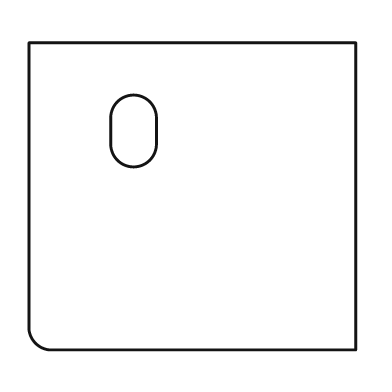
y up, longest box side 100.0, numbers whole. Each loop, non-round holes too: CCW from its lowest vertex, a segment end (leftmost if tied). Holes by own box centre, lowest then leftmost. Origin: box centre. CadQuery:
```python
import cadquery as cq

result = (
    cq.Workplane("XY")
    .moveTo(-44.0, -47.0)
    .lineTo(50.0, -47.0)
    .lineTo(50.0, 47.0)
    .lineTo(-50.0, 47.0)
    .lineTo(-50.0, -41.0)
    .threePointArc((-48.0, -45.0), (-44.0, -47.0))
    .close()
    .moveTo(-25.0, 16.0)
    .threePointArc((-18.0, 9.0), (-11.0, 16.0))
    .lineTo(-11.0, 24.0)
    .threePointArc((-18.0, 31.0), (-25.0, 24.0))
    .close()
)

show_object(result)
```